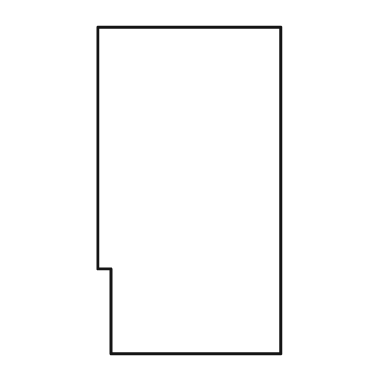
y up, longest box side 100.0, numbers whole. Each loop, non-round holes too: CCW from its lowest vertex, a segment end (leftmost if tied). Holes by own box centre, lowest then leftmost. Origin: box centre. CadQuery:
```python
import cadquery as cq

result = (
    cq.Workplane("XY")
    .moveTo(-24.0, -50.0)
    .lineTo(28.0, -50.0)
    .lineTo(28.0, 50.0)
    .lineTo(-28.0, 50.0)
    .lineTo(-28.0, -24.0)
    .lineTo(-24.0, -24.0)
    .close()
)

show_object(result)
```